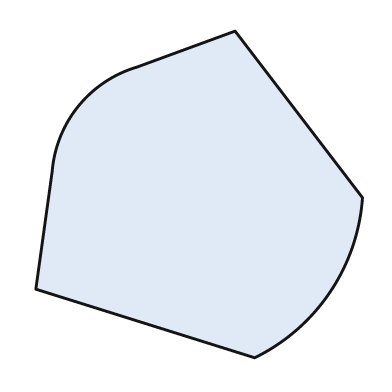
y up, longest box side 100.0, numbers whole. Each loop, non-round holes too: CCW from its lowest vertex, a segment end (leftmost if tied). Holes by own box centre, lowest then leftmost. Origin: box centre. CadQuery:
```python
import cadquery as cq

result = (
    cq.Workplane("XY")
    .moveTo(17.0, -50.0)
    .threePointArc((40.0, -30.0), (50.0, -1.0))
    .lineTo(11.0, 50.0)
    .lineTo(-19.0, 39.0)
    .threePointArc((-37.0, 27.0), (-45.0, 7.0))
    .lineTo(-50.0, -29.0)
    .close()
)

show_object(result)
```